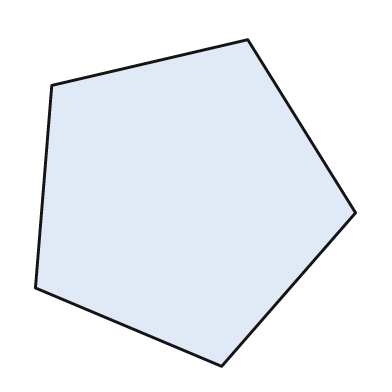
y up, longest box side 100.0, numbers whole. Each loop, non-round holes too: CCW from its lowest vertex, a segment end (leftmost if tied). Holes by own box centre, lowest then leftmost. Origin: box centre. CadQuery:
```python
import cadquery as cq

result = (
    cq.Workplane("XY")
    .moveTo(8.0, -50.0)
    .lineTo(49.0, -3.0)
    .lineTo(16.0, 50.0)
    .lineTo(-44.0, 36.0)
    .lineTo(-49.0, -26.0)
    .close()
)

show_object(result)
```